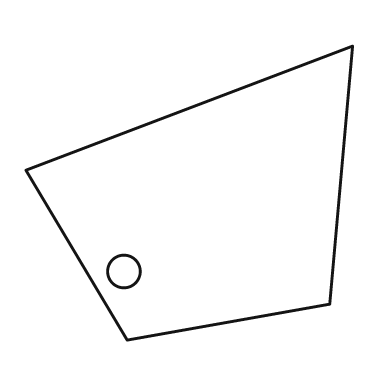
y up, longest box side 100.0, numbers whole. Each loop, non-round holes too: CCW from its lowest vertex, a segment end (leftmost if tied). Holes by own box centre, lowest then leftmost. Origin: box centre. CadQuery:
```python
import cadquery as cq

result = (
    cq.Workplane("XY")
    .moveTo(-19.0, -45.0)
    .lineTo(43.0, -34.0)
    .lineTo(50.0, 45.0)
    .lineTo(-50.0, 7.0)
    .close()
    .moveTo(-20.0, -24.0)
    .circle(5.0)
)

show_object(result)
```